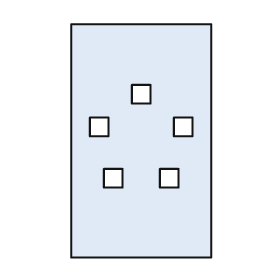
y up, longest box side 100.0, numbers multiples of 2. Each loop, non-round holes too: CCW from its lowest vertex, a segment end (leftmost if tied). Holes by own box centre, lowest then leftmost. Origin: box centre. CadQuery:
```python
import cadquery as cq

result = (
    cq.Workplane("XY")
    .moveTo(-30.0, -50.0)
    .lineTo(30.0, -50.0)
    .lineTo(30.0, 50.0)
    .lineTo(-30.0, 50.0)
    .close()
    .moveTo(-16.0, -20.0)
    .lineTo(-8.0, -20.0)
    .lineTo(-8.0, -12.0)
    .lineTo(-16.0, -12.0)
    .close()
    .moveTo(8.0, -20.0)
    .lineTo(16.0, -20.0)
    .lineTo(16.0, -12.0)
    .lineTo(8.0, -12.0)
    .close()
    .moveTo(-22.0, 2.0)
    .lineTo(-14.0, 2.0)
    .lineTo(-14.0, 10.0)
    .lineTo(-22.0, 10.0)
    .close()
    .moveTo(14.0, 2.0)
    .lineTo(22.0, 2.0)
    .lineTo(22.0, 10.0)
    .lineTo(14.0, 10.0)
    .close()
    .moveTo(-4.0, 16.0)
    .lineTo(4.0, 16.0)
    .lineTo(4.0, 24.0)
    .lineTo(-4.0, 24.0)
    .close()
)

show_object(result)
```